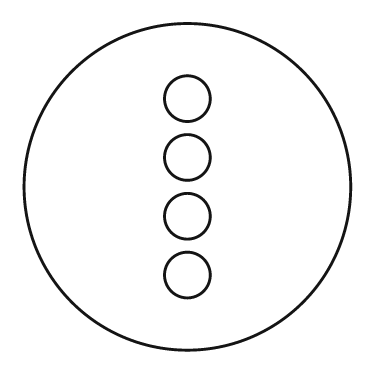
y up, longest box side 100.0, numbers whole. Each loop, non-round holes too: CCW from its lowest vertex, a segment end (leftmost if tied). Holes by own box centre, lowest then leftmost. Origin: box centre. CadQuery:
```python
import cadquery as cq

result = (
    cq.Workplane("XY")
    .moveTo(0.0, 0.0)
    .circle(50.0)
    .moveTo(0.0, -27.0)
    .circle(7.0)
    .moveTo(0.0, -9.0)
    .circle(7.0)
    .moveTo(0.0, 9.0)
    .circle(7.0)
    .moveTo(0.0, 27.0)
    .circle(7.0)
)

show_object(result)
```